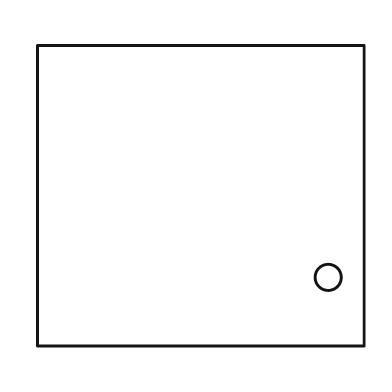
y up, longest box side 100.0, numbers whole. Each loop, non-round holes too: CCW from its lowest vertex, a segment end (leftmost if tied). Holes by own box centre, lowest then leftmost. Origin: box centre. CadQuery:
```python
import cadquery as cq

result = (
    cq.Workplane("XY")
    .moveTo(-50.0, -46.0)
    .lineTo(50.0, -46.0)
    .lineTo(50.0, 46.0)
    .lineTo(-50.0, 46.0)
    .close()
    .moveTo(39.0, -25.0)
    .circle(4.0)
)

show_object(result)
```